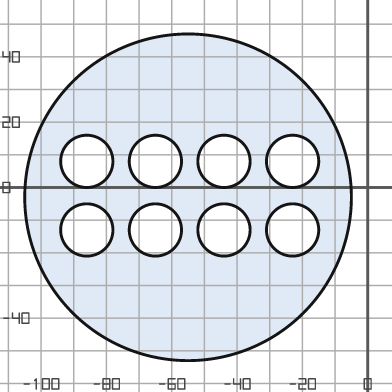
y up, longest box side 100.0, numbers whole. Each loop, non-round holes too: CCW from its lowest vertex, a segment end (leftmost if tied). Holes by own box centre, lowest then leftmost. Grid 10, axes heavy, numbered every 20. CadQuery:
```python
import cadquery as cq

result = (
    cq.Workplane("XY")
    .moveTo(-55.0, -3.0)
    .circle(50.0)
    .moveTo(-86.0, -13.0)
    .circle(8.0)
    .moveTo(-65.0, -13.0)
    .circle(8.0)
    .moveTo(-44.0, -13.0)
    .circle(8.0)
    .moveTo(-23.0, -13.0)
    .circle(8.0)
    .moveTo(-86.0, 8.0)
    .circle(8.0)
    .moveTo(-65.0, 8.0)
    .circle(8.0)
    .moveTo(-44.0, 8.0)
    .circle(8.0)
    .moveTo(-23.0, 8.0)
    .circle(8.0)
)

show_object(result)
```